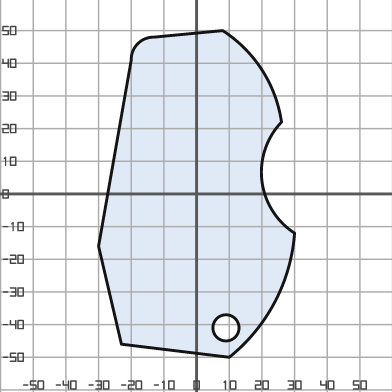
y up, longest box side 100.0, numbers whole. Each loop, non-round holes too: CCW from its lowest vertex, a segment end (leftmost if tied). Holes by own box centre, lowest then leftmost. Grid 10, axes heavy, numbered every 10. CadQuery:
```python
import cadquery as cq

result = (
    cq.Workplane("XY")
    .moveTo(10.0, -50.0)
    .threePointArc((24.0, -33.0), (30.0, -12.0))
    .threePointArc((20.0, 4.0), (26.0, 22.0))
    .threePointArc((20.0, 38.0), (8.0, 50.0))
    .lineTo(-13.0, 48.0)
    .threePointArc((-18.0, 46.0), (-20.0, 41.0))
    .lineTo(-30.0, -16.0)
    .lineTo(-23.0, -46.0)
    .close()
    .moveTo(9.0, -41.0)
    .circle(4.0)
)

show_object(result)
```